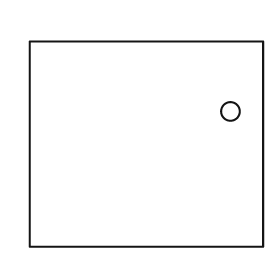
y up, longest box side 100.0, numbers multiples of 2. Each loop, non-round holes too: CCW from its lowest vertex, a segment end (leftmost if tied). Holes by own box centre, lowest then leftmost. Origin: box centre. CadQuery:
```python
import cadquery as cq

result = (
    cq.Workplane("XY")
    .moveTo(-50.0, -44.0)
    .lineTo(50.0, -44.0)
    .lineTo(50.0, 44.0)
    .lineTo(-50.0, 44.0)
    .close()
    .moveTo(36.0, 14.0)
    .circle(4.0)
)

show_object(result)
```